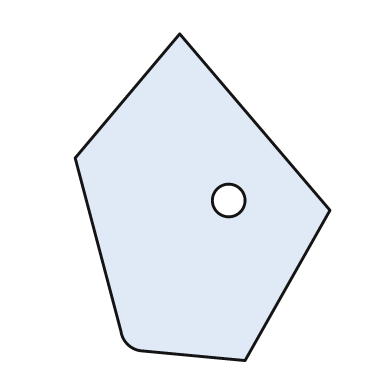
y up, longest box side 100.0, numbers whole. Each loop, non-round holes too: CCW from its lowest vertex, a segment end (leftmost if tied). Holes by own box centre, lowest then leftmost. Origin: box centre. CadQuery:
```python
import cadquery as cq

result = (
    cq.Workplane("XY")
    .moveTo(13.0, -50.0)
    .lineTo(39.0, -4.0)
    .lineTo(-7.0, 50.0)
    .lineTo(-39.0, 12.0)
    .lineTo(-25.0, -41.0)
    .threePointArc((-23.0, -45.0), (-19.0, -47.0))
    .close()
    .moveTo(8.0, -1.0)
    .circle(5.0)
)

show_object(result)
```